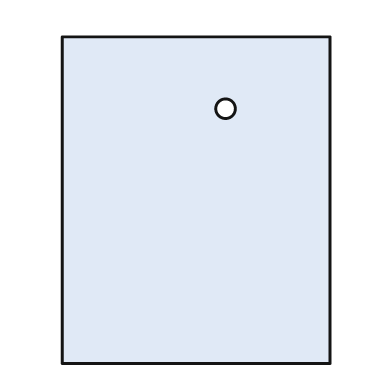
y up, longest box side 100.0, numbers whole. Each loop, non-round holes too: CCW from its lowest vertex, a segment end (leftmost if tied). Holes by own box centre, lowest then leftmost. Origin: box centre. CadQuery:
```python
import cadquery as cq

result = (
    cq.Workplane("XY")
    .moveTo(-41.0, -50.0)
    .lineTo(41.0, -50.0)
    .lineTo(41.0, 50.0)
    .lineTo(-41.0, 50.0)
    .close()
    .moveTo(9.0, 28.0)
    .circle(3.0)
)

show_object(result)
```